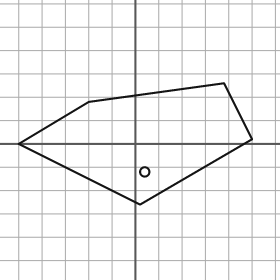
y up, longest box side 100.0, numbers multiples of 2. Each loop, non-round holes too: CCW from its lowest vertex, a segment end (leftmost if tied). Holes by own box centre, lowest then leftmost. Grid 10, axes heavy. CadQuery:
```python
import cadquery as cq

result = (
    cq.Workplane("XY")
    .moveTo(2.0, -26.0)
    .lineTo(50.0, 2.0)
    .lineTo(38.0, 26.0)
    .lineTo(-20.0, 18.0)
    .lineTo(-50.0, 0.0)
    .close()
    .moveTo(4.0, -12.0)
    .circle(2.0)
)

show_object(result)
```